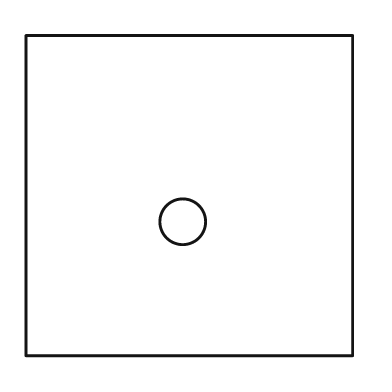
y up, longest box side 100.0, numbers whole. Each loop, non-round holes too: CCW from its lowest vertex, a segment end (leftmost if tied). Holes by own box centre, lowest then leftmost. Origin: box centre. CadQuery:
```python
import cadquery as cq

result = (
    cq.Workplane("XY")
    .moveTo(-50.0, -49.0)
    .lineTo(50.0, -49.0)
    .lineTo(50.0, 49.0)
    .lineTo(-50.0, 49.0)
    .close()
    .moveTo(-2.0, -8.0)
    .circle(7.0)
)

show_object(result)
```